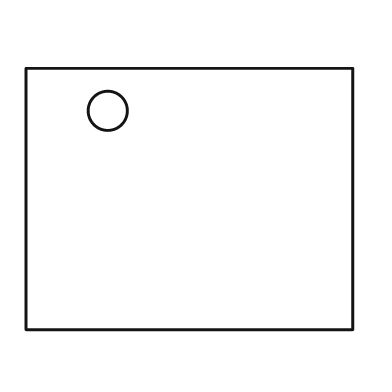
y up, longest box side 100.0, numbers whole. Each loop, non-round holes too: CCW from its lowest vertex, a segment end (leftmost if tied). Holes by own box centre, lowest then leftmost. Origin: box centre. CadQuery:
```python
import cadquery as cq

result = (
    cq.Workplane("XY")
    .moveTo(-50.0, -40.0)
    .lineTo(50.0, -40.0)
    .lineTo(50.0, 40.0)
    .lineTo(-50.0, 40.0)
    .close()
    .moveTo(-25.0, 27.0)
    .circle(6.0)
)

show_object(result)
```